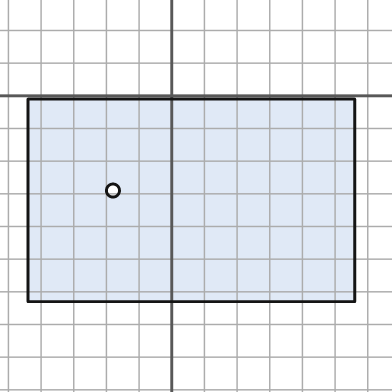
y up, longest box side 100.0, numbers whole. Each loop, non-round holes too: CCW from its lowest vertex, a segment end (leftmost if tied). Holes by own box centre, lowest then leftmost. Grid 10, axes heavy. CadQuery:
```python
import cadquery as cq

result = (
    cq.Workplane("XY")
    .moveTo(-44.0, -63.0)
    .lineTo(56.0, -63.0)
    .lineTo(56.0, -1.0)
    .lineTo(-44.0, -1.0)
    .close()
    .moveTo(-18.0, -29.0)
    .circle(2.0)
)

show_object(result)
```